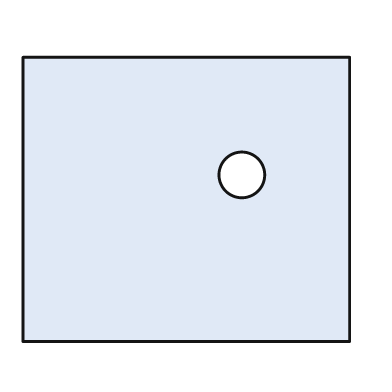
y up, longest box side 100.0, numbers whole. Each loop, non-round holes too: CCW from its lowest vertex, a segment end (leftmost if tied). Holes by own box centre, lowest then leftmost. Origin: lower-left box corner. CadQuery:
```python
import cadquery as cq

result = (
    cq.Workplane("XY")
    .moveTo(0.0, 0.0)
    .lineTo(100.0, 0.0)
    .lineTo(100.0, 87.0)
    .lineTo(0.0, 87.0)
    .close()
    .moveTo(67.0, 51.0)
    .circle(7.0)
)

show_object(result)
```